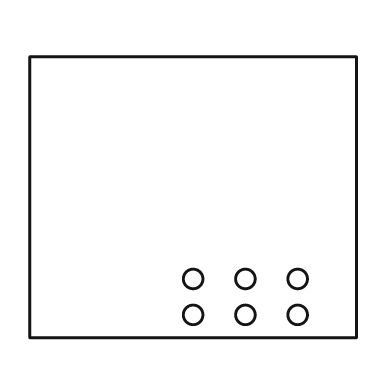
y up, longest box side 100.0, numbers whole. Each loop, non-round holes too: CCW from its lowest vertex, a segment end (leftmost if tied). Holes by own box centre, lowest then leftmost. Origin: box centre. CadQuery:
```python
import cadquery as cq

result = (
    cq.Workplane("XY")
    .moveTo(-50.0, -43.0)
    .lineTo(50.0, -43.0)
    .lineTo(50.0, 43.0)
    .lineTo(-50.0, 43.0)
    .close()
    .moveTo(0.0, -36.0)
    .circle(3.0)
    .moveTo(16.0, -36.0)
    .circle(3.0)
    .moveTo(32.0, -36.0)
    .circle(3.0)
    .moveTo(0.0, -25.0)
    .circle(3.0)
    .moveTo(16.0, -25.0)
    .circle(3.0)
    .moveTo(32.0, -25.0)
    .circle(3.0)
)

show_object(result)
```